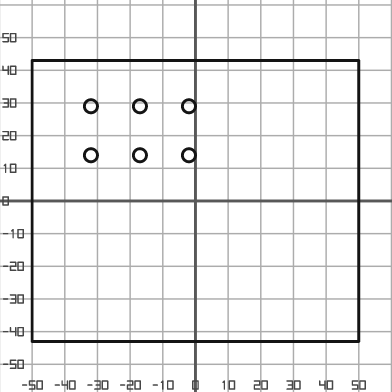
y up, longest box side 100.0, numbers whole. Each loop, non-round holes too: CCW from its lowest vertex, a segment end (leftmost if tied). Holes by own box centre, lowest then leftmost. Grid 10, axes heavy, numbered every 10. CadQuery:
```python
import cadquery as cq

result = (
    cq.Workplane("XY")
    .moveTo(-50.0, -43.0)
    .lineTo(50.0, -43.0)
    .lineTo(50.0, 43.0)
    .lineTo(-50.0, 43.0)
    .close()
    .moveTo(-32.0, 14.0)
    .circle(2.0)
    .moveTo(-17.0, 14.0)
    .circle(2.0)
    .moveTo(-2.0, 14.0)
    .circle(2.0)
    .moveTo(-32.0, 29.0)
    .circle(2.0)
    .moveTo(-17.0, 29.0)
    .circle(2.0)
    .moveTo(-2.0, 29.0)
    .circle(2.0)
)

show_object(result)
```